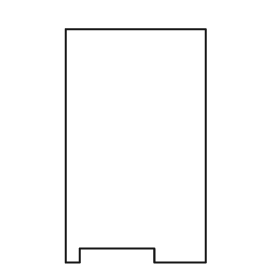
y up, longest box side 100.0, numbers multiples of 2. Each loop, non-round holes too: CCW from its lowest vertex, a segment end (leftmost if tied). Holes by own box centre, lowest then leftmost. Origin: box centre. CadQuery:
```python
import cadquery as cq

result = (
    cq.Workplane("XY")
    .moveTo(-30.0, -50.0)
    .lineTo(-24.0, -50.0)
    .lineTo(-24.0, -44.0)
    .lineTo(8.0, -44.0)
    .lineTo(8.0, -50.0)
    .lineTo(30.0, -50.0)
    .lineTo(30.0, 50.0)
    .lineTo(-30.0, 50.0)
    .close()
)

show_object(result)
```